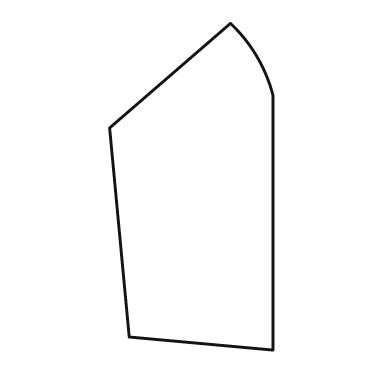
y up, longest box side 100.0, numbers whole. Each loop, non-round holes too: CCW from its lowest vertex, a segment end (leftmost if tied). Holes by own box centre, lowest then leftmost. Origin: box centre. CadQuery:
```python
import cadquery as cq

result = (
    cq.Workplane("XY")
    .moveTo(25.0, -50.0)
    .lineTo(25.0, 28.0)
    .threePointArc((20.0, 40.0), (12.0, 50.0))
    .lineTo(-25.0, 18.0)
    .lineTo(-19.0, -46.0)
    .close()
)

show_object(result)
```